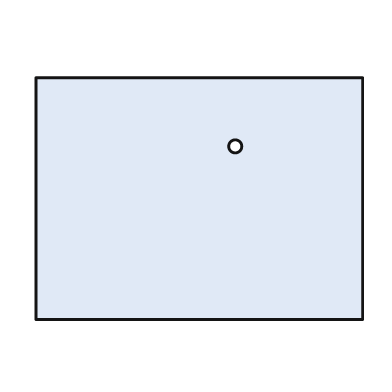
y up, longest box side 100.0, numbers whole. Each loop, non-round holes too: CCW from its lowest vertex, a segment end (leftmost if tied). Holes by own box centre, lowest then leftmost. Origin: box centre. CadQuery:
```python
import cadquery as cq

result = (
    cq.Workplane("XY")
    .moveTo(-50.0, -37.0)
    .lineTo(50.0, -37.0)
    .lineTo(50.0, 37.0)
    .lineTo(-50.0, 37.0)
    .close()
    .moveTo(11.0, 16.0)
    .circle(2.0)
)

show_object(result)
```